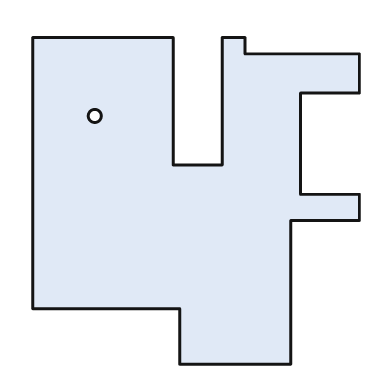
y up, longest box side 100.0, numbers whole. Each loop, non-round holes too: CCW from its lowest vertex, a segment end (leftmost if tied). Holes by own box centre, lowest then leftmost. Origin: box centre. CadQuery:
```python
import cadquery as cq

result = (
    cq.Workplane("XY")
    .moveTo(-5.0, -50.0)
    .lineTo(29.0, -50.0)
    .lineTo(29.0, -6.0)
    .lineTo(50.0, -6.0)
    .lineTo(50.0, 2.0)
    .lineTo(32.0, 2.0)
    .lineTo(32.0, 33.0)
    .lineTo(50.0, 33.0)
    .lineTo(50.0, 45.0)
    .lineTo(15.0, 45.0)
    .lineTo(15.0, 50.0)
    .lineTo(8.0, 50.0)
    .lineTo(8.0, 11.0)
    .lineTo(-7.0, 11.0)
    .lineTo(-7.0, 50.0)
    .lineTo(-50.0, 50.0)
    .lineTo(-50.0, -33.0)
    .lineTo(-5.0, -33.0)
    .close()
    .moveTo(-31.0, 26.0)
    .circle(2.0)
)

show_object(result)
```